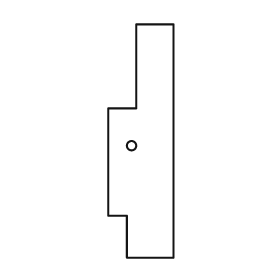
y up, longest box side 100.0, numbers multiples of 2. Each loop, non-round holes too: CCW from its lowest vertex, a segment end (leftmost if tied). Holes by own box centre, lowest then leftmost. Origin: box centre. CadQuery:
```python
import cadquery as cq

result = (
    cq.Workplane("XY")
    .moveTo(-6.0, -50.0)
    .lineTo(14.0, -50.0)
    .lineTo(14.0, 50.0)
    .lineTo(-2.0, 50.0)
    .lineTo(-2.0, 14.0)
    .lineTo(-14.0, 14.0)
    .lineTo(-14.0, -32.0)
    .lineTo(-6.0, -32.0)
    .close()
    .moveTo(-4.0, -2.0)
    .circle(2.0)
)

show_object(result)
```